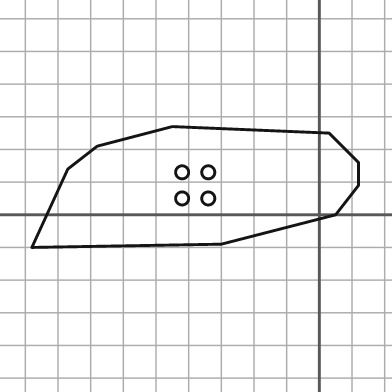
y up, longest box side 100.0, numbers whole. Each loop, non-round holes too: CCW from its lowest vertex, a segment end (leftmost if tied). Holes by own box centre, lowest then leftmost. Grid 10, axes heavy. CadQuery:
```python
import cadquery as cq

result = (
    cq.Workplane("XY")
    .moveTo(-88.0, -10.0)
    .lineTo(-30.0, -9.0)
    .lineTo(5.0, 0.0)
    .lineTo(12.0, 9.0)
    .lineTo(12.0, 16.0)
    .lineTo(3.0, 25.0)
    .lineTo(-45.0, 27.0)
    .lineTo(-68.0, 21.0)
    .lineTo(-77.0, 14.0)
    .close()
    .moveTo(-42.0, 5.0)
    .circle(2.0)
    .moveTo(-34.0, 5.0)
    .circle(2.0)
    .moveTo(-42.0, 13.0)
    .circle(2.0)
    .moveTo(-34.0, 13.0)
    .circle(2.0)
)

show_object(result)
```